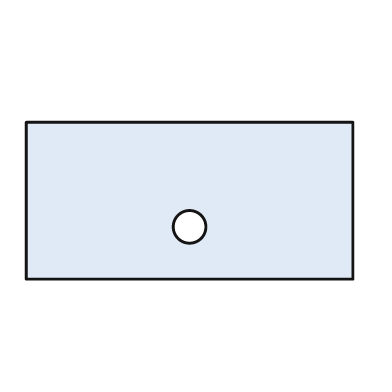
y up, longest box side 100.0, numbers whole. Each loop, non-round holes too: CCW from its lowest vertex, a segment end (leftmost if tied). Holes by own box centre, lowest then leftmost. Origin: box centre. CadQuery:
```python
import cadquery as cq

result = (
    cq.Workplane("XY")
    .moveTo(-50.0, -24.0)
    .lineTo(50.0, -24.0)
    .lineTo(50.0, 24.0)
    .lineTo(-50.0, 24.0)
    .close()
    .moveTo(0.0, -8.0)
    .circle(5.0)
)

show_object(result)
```